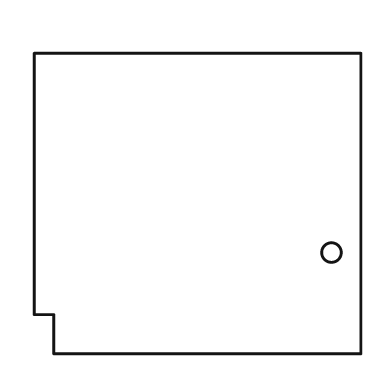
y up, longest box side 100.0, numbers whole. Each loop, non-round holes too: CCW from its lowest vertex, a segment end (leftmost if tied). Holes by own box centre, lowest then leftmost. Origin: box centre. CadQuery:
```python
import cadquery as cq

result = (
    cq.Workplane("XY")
    .moveTo(-44.0, -46.0)
    .lineTo(50.0, -46.0)
    .lineTo(50.0, 46.0)
    .lineTo(-50.0, 46.0)
    .lineTo(-50.0, -34.0)
    .lineTo(-44.0, -34.0)
    .close()
    .moveTo(41.0, -15.0)
    .circle(3.0)
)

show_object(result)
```